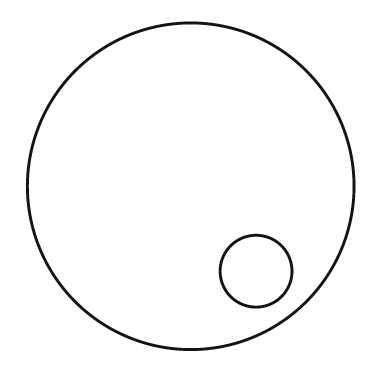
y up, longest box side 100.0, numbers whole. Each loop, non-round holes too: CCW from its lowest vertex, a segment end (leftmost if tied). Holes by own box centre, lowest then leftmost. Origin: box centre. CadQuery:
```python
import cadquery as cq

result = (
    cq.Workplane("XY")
    .moveTo(0.0, 0.0)
    .circle(50.0)
    .moveTo(20.0, -26.0)
    .circle(11.0)
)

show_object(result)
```